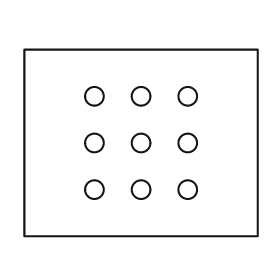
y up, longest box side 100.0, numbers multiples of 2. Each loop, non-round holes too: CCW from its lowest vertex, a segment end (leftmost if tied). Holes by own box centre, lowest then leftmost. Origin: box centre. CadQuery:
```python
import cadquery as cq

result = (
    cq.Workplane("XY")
    .moveTo(-50.0, -40.0)
    .lineTo(50.0, -40.0)
    .lineTo(50.0, 40.0)
    .lineTo(-50.0, 40.0)
    .close()
    .moveTo(-20.0, -20.0)
    .circle(4.0)
    .moveTo(0.0, -20.0)
    .circle(4.0)
    .moveTo(20.0, -20.0)
    .circle(4.0)
    .moveTo(-20.0, 0.0)
    .circle(4.0)
    .moveTo(0.0, 0.0)
    .circle(4.0)
    .moveTo(20.0, 0.0)
    .circle(4.0)
    .moveTo(-20.0, 20.0)
    .circle(4.0)
    .moveTo(0.0, 20.0)
    .circle(4.0)
    .moveTo(20.0, 20.0)
    .circle(4.0)
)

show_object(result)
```